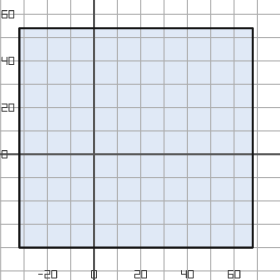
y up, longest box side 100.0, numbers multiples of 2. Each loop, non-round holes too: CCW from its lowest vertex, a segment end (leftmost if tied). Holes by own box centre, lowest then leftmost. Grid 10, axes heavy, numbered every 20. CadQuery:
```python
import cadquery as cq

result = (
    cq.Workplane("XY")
    .moveTo(-32.0, -40.0)
    .lineTo(68.0, -40.0)
    .lineTo(68.0, 54.0)
    .lineTo(-32.0, 54.0)
    .close()
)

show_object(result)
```